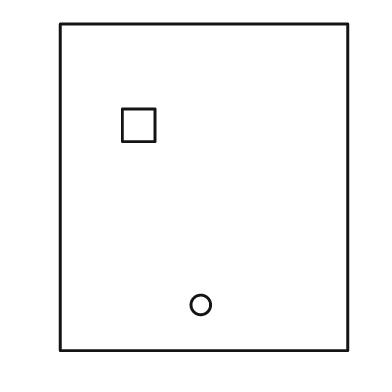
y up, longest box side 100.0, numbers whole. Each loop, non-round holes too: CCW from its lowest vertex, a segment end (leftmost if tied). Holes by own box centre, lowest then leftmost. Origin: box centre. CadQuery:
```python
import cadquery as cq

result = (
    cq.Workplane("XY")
    .moveTo(-44.0, -50.0)
    .lineTo(44.0, -50.0)
    .lineTo(44.0, 50.0)
    .lineTo(-44.0, 50.0)
    .close()
    .moveTo(-1.0, -36.0)
    .circle(3.0)
    .moveTo(-25.0, 14.0)
    .lineTo(-15.0, 14.0)
    .lineTo(-15.0, 24.0)
    .lineTo(-25.0, 24.0)
    .close()
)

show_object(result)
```